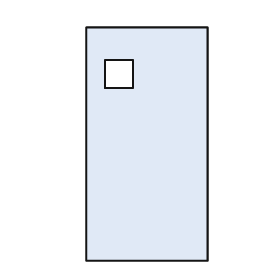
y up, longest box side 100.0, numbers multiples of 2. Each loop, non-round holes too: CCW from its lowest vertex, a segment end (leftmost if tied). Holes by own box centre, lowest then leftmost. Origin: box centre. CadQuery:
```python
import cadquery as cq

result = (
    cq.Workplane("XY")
    .moveTo(-26.0, -50.0)
    .lineTo(26.0, -50.0)
    .lineTo(26.0, 50.0)
    .lineTo(-26.0, 50.0)
    .close()
    .moveTo(-18.0, 24.0)
    .lineTo(-6.0, 24.0)
    .lineTo(-6.0, 36.0)
    .lineTo(-18.0, 36.0)
    .close()
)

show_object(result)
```